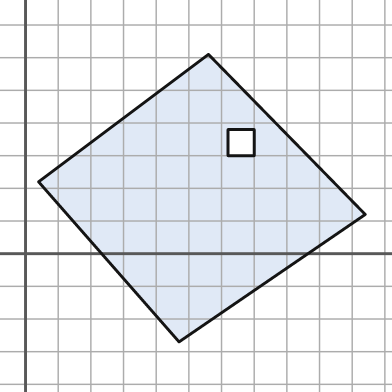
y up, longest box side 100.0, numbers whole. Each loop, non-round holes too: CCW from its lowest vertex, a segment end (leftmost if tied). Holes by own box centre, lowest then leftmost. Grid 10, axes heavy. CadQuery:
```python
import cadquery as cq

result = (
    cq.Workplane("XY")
    .moveTo(47.0, -27.0)
    .lineTo(104.0, 12.0)
    .lineTo(56.0, 61.0)
    .lineTo(4.0, 22.0)
    .close()
    .moveTo(62.0, 30.0)
    .lineTo(70.0, 30.0)
    .lineTo(70.0, 38.0)
    .lineTo(62.0, 38.0)
    .close()
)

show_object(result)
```